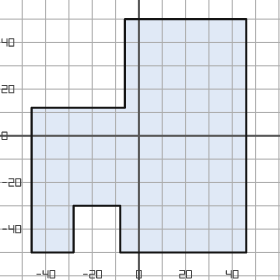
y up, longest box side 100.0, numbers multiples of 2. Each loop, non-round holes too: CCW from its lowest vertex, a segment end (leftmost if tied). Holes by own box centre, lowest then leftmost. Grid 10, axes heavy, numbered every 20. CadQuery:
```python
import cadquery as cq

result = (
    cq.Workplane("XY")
    .moveTo(-46.0, -50.0)
    .lineTo(-28.0, -50.0)
    .lineTo(-28.0, -30.0)
    .lineTo(-8.0, -30.0)
    .lineTo(-8.0, -50.0)
    .lineTo(46.0, -50.0)
    .lineTo(46.0, 50.0)
    .lineTo(-6.0, 50.0)
    .lineTo(-6.0, 12.0)
    .lineTo(-46.0, 12.0)
    .close()
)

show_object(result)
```